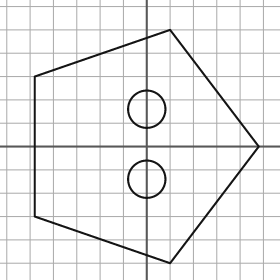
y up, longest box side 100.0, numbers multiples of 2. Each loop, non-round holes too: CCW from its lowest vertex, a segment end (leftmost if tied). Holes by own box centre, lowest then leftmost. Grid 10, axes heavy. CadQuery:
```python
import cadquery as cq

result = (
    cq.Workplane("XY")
    .moveTo(10.0, -50.0)
    .lineTo(48.0, 0.0)
    .lineTo(10.0, 50.0)
    .lineTo(-48.0, 30.0)
    .lineTo(-48.0, -30.0)
    .close()
    .moveTo(0.0, -14.0)
    .circle(8.0)
    .moveTo(0.0, 16.0)
    .circle(8.0)
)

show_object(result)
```